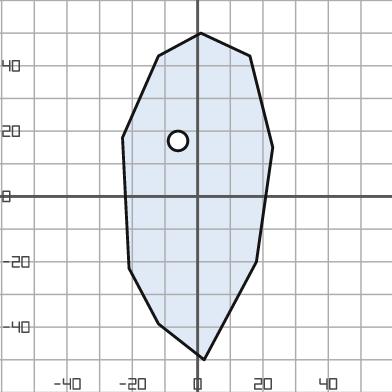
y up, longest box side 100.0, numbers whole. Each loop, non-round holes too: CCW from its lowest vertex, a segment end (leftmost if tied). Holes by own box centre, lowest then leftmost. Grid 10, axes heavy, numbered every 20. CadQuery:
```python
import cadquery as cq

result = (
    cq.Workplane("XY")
    .moveTo(2.0, -50.0)
    .lineTo(18.0, -20.0)
    .lineTo(23.0, 15.0)
    .lineTo(16.0, 43.0)
    .lineTo(1.0, 50.0)
    .lineTo(-12.0, 43.0)
    .lineTo(-23.0, 18.0)
    .lineTo(-21.0, -22.0)
    .lineTo(-12.0, -39.0)
    .close()
    .moveTo(-6.0, 17.0)
    .circle(3.0)
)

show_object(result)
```